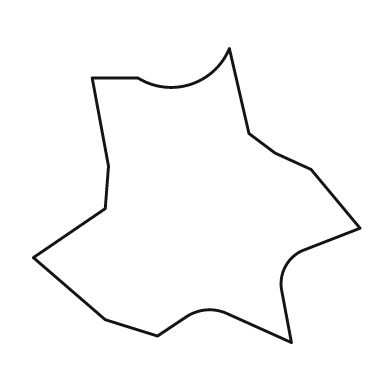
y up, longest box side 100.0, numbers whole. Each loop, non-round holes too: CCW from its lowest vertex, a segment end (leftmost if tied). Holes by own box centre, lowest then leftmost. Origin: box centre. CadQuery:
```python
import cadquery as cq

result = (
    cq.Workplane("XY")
    .moveTo(29.0, -45.0)
    .lineTo(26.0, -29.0)
    .threePointArc((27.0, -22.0), (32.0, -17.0))
    .lineTo(50.0, -10.0)
    .lineTo(35.0, 8.0)
    .lineTo(24.0, 13.0)
    .lineTo(16.0, 19.0)
    .lineTo(10.0, 45.0)
    .threePointArc((-2.0, 34.0), (-18.0, 36.0))
    .lineTo(-32.0, 36.0)
    .lineTo(-27.0, 9.0)
    .lineTo(-28.0, -4.0)
    .lineTo(-50.0, -19.0)
    .lineTo(-28.0, -38.0)
    .lineTo(-12.0, -43.0)
    .lineTo(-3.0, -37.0)
    .threePointArc((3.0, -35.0), (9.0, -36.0))
    .close()
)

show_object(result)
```